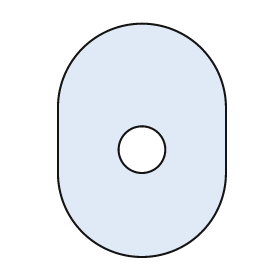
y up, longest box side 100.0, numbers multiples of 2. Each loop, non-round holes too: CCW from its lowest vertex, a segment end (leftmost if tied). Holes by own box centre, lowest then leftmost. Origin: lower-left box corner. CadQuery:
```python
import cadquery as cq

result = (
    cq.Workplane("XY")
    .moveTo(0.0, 36.0)
    .threePointArc((36.0, 0.0), (72.0, 36.0))
    .lineTo(72.0, 64.0)
    .threePointArc((36.0, 100.0), (0.0, 64.0))
    .close()
    .moveTo(36.0, 46.0)
    .circle(10.0)
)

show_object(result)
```